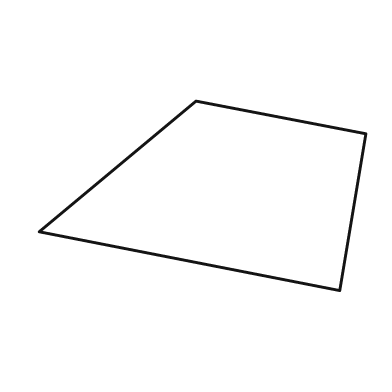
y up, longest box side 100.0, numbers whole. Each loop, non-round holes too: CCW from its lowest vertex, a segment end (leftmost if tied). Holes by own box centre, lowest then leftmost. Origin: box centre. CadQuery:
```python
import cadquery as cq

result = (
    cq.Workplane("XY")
    .moveTo(42.0, -29.0)
    .lineTo(50.0, 19.0)
    .lineTo(-2.0, 29.0)
    .lineTo(-50.0, -11.0)
    .close()
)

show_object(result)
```